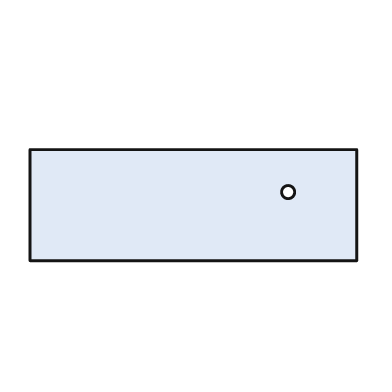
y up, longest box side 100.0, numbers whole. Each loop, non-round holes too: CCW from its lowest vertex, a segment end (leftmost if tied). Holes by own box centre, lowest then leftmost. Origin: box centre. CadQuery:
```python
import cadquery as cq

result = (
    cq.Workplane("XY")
    .moveTo(-50.0, -17.0)
    .lineTo(50.0, -17.0)
    .lineTo(50.0, 17.0)
    .lineTo(-50.0, 17.0)
    .close()
    .moveTo(29.0, 4.0)
    .circle(2.0)
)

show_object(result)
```